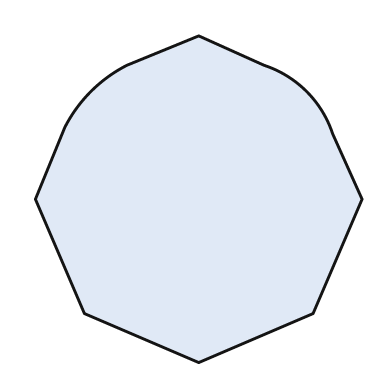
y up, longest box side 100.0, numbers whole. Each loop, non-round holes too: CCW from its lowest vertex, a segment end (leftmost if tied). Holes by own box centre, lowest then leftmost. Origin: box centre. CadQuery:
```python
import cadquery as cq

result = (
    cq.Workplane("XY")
    .moveTo(0.0, -50.0)
    .lineTo(35.0, -35.0)
    .lineTo(50.0, 0.0)
    .lineTo(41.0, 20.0)
    .threePointArc((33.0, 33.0), (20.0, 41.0))
    .lineTo(0.0, 50.0)
    .lineTo(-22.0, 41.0)
    .threePointArc((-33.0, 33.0), (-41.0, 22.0))
    .lineTo(-50.0, 0.0)
    .lineTo(-35.0, -35.0)
    .close()
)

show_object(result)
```